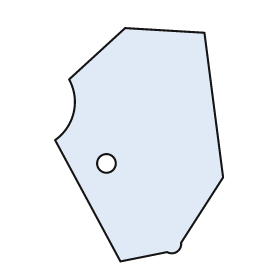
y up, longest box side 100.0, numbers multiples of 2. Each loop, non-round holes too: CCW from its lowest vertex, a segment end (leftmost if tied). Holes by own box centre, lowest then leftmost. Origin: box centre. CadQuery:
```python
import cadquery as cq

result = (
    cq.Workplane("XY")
    .moveTo(-8.0, -50.0)
    .lineTo(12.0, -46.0)
    .threePointArc((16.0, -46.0), (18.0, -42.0))
    .lineTo(36.0, -14.0)
    .lineTo(28.0, 48.0)
    .lineTo(-6.0, 50.0)
    .lineTo(-30.0, 28.0)
    .threePointArc((-28.0, 14.0), (-36.0, 2.0))
    .close()
    .moveTo(-14.0, -8.0)
    .circle(4.0)
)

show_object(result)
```